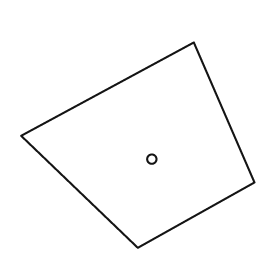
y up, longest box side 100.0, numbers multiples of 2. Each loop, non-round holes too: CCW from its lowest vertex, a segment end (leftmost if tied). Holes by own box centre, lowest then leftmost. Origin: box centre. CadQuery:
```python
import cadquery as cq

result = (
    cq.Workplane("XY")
    .moveTo(0.0, -44.0)
    .lineTo(50.0, -16.0)
    .lineTo(24.0, 44.0)
    .lineTo(-50.0, 4.0)
    .close()
    .moveTo(6.0, -6.0)
    .circle(2.0)
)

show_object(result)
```